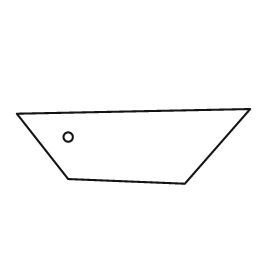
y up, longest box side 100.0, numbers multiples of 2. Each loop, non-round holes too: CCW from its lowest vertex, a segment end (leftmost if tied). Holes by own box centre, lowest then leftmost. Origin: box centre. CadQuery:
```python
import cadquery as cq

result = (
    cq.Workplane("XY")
    .moveTo(22.0, -16.0)
    .lineTo(50.0, 16.0)
    .lineTo(-50.0, 14.0)
    .lineTo(-28.0, -14.0)
    .close()
    .moveTo(-28.0, 4.0)
    .circle(2.0)
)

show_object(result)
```